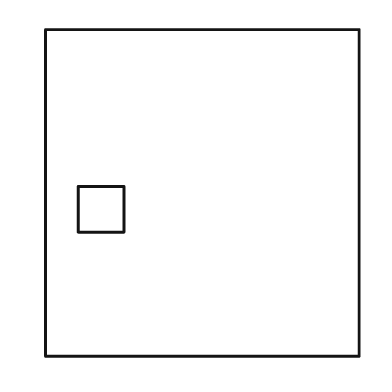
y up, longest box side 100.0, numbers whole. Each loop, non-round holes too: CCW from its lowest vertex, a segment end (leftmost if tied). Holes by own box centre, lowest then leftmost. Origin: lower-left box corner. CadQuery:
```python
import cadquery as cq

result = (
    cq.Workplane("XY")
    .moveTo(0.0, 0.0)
    .lineTo(96.0, 0.0)
    .lineTo(96.0, 100.0)
    .lineTo(0.0, 100.0)
    .close()
    .moveTo(10.0, 38.0)
    .lineTo(24.0, 38.0)
    .lineTo(24.0, 52.0)
    .lineTo(10.0, 52.0)
    .close()
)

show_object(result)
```